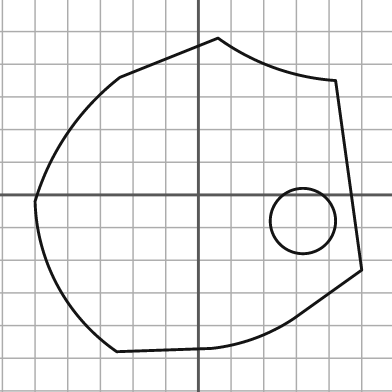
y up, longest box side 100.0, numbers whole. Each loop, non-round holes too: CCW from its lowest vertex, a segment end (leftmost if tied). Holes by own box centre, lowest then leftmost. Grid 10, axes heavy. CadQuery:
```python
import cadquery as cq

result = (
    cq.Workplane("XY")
    .moveTo(-25.0, -48.0)
    .lineTo(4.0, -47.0)
    .threePointArc((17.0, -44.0), (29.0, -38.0))
    .lineTo(50.0, -23.0)
    .lineTo(42.0, 35.0)
    .threePointArc((23.0, 39.0), (6.0, 48.0))
    .lineTo(-24.0, 36.0)
    .threePointArc((-40.0, 19.0), (-50.0, -2.0))
    .threePointArc((-43.0, -28.0), (-25.0, -48.0))
    .close()
    .moveTo(32.0, -8.0)
    .circle(10.0)
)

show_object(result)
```